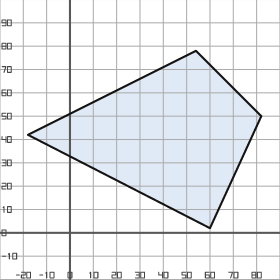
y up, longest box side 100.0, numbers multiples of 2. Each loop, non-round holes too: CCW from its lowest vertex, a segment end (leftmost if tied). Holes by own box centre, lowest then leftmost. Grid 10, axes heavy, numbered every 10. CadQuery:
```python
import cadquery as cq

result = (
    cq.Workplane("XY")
    .moveTo(60.0, 2.0)
    .lineTo(82.0, 50.0)
    .lineTo(54.0, 78.0)
    .lineTo(-18.0, 42.0)
    .close()
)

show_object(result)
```